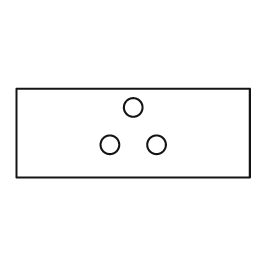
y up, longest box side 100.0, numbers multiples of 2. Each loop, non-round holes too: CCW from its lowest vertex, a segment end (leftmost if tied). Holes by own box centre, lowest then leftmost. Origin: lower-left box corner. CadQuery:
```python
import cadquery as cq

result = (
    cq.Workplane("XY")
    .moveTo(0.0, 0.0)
    .lineTo(100.0, 0.0)
    .lineTo(100.0, 38.0)
    .lineTo(0.0, 38.0)
    .close()
    .moveTo(40.0, 14.0)
    .circle(4.0)
    .moveTo(60.0, 14.0)
    .circle(4.0)
    .moveTo(50.0, 30.0)
    .circle(4.0)
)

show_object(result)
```